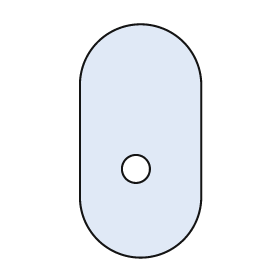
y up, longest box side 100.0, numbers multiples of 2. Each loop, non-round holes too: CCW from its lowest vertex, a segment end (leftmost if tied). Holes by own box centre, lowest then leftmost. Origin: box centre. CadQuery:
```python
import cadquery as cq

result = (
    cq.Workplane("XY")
    .moveTo(-26.0, -24.0)
    .threePointArc((0.0, -50.0), (26.0, -24.0))
    .lineTo(26.0, 24.0)
    .threePointArc((0.0, 50.0), (-26.0, 24.0))
    .close()
    .moveTo(-2.0, -12.0)
    .circle(6.0)
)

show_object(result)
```